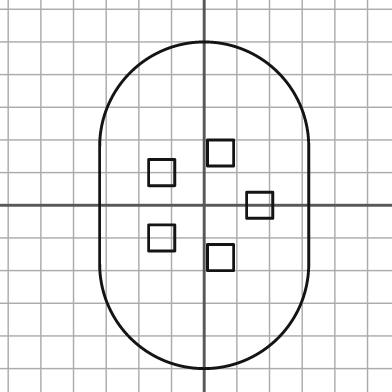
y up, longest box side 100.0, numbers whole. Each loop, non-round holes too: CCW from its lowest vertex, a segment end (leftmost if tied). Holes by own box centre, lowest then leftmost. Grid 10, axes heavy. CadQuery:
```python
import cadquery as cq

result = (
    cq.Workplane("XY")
    .moveTo(-32.0, -18.0)
    .threePointArc((0.0, -50.0), (32.0, -18.0))
    .lineTo(32.0, 18.0)
    .threePointArc((0.0, 50.0), (-32.0, 18.0))
    .close()
    .moveTo(1.0, -20.0)
    .lineTo(9.0, -20.0)
    .lineTo(9.0, -12.0)
    .lineTo(1.0, -12.0)
    .close()
    .moveTo(-17.0, -14.0)
    .lineTo(-9.0, -14.0)
    .lineTo(-9.0, -6.0)
    .lineTo(-17.0, -6.0)
    .close()
    .moveTo(13.0, -4.0)
    .lineTo(21.0, -4.0)
    .lineTo(21.0, 4.0)
    .lineTo(13.0, 4.0)
    .close()
    .moveTo(-17.0, 6.0)
    .lineTo(-9.0, 6.0)
    .lineTo(-9.0, 14.0)
    .lineTo(-17.0, 14.0)
    .close()
    .moveTo(1.0, 12.0)
    .lineTo(9.0, 12.0)
    .lineTo(9.0, 20.0)
    .lineTo(1.0, 20.0)
    .close()
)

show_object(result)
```